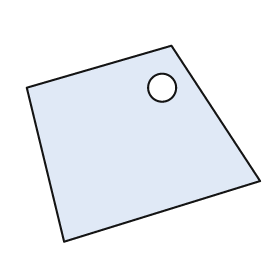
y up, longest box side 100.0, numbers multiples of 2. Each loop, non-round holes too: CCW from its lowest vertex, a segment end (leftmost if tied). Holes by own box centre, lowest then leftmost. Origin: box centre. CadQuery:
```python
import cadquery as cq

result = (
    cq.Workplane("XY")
    .moveTo(-34.0, -42.0)
    .lineTo(50.0, -16.0)
    .lineTo(12.0, 42.0)
    .lineTo(-50.0, 24.0)
    .close()
    .moveTo(8.0, 24.0)
    .circle(6.0)
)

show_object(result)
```